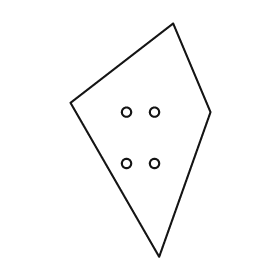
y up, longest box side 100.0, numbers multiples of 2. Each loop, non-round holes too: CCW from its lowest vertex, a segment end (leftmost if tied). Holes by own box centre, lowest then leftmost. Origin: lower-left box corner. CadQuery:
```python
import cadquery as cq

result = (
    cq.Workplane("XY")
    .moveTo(38.0, 0.0)
    .lineTo(60.0, 62.0)
    .lineTo(44.0, 100.0)
    .lineTo(0.0, 66.0)
    .close()
    .moveTo(24.0, 40.0)
    .circle(2.0)
    .moveTo(36.0, 40.0)
    .circle(2.0)
    .moveTo(24.0, 62.0)
    .circle(2.0)
    .moveTo(36.0, 62.0)
    .circle(2.0)
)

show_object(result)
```